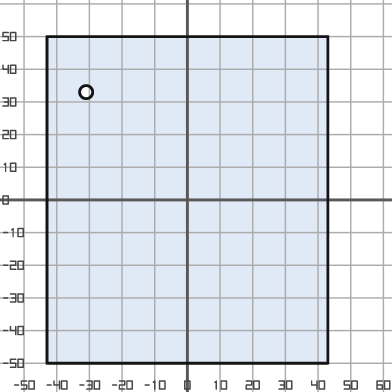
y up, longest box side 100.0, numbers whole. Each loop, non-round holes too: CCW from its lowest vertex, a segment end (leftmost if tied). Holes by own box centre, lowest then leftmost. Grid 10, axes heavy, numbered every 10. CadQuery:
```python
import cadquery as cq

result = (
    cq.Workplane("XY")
    .moveTo(-43.0, -50.0)
    .lineTo(43.0, -50.0)
    .lineTo(43.0, 50.0)
    .lineTo(-43.0, 50.0)
    .close()
    .moveTo(-31.0, 33.0)
    .circle(2.0)
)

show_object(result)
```